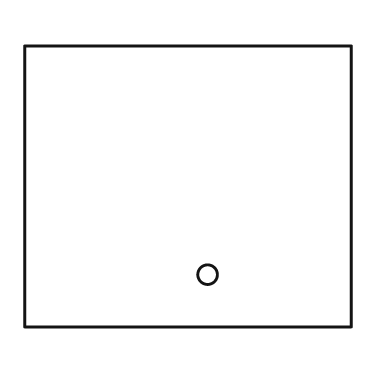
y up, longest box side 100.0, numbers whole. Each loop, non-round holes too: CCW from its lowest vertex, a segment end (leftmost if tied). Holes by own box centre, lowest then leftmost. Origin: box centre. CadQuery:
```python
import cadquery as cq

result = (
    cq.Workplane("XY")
    .moveTo(-50.0, -43.0)
    .lineTo(50.0, -43.0)
    .lineTo(50.0, 43.0)
    .lineTo(-50.0, 43.0)
    .close()
    .moveTo(6.0, -27.0)
    .circle(3.0)
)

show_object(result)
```